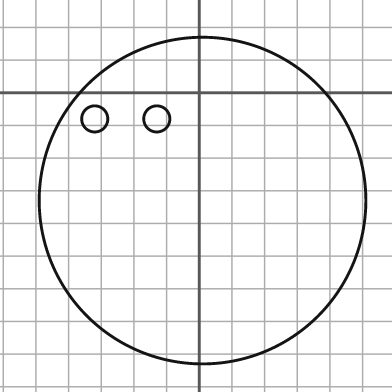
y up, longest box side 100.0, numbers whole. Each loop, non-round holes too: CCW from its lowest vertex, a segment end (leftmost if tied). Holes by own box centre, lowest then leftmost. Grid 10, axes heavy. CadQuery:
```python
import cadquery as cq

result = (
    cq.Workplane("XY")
    .moveTo(1.0, -33.0)
    .circle(50.0)
    .moveTo(-32.0, -8.0)
    .circle(4.0)
    .moveTo(-13.0, -8.0)
    .circle(4.0)
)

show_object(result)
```